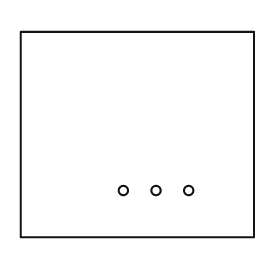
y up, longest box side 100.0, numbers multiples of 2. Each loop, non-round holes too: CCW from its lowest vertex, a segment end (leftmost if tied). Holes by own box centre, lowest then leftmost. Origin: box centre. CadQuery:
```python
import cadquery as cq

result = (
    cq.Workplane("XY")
    .moveTo(-50.0, -44.0)
    .lineTo(50.0, -44.0)
    .lineTo(50.0, 44.0)
    .lineTo(-50.0, 44.0)
    .close()
    .moveTo(-6.0, -24.0)
    .circle(2.0)
    .moveTo(8.0, -24.0)
    .circle(2.0)
    .moveTo(22.0, -24.0)
    .circle(2.0)
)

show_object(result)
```